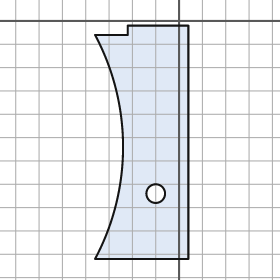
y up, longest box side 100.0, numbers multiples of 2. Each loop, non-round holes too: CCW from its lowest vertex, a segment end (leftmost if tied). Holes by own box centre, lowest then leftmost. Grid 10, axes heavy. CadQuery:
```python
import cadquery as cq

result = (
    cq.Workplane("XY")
    .moveTo(-36.0, -102.0)
    .lineTo(4.0, -102.0)
    .lineTo(4.0, -2.0)
    .lineTo(-22.0, -2.0)
    .lineTo(-22.0, -6.0)
    .lineTo(-36.0, -6.0)
    .threePointArc((-24.0, -54.0), (-36.0, -102.0))
    .close()
    .moveTo(-10.0, -74.0)
    .circle(4.0)
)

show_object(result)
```